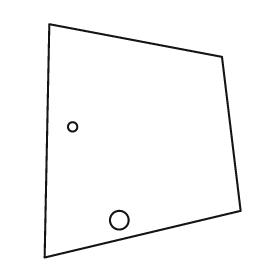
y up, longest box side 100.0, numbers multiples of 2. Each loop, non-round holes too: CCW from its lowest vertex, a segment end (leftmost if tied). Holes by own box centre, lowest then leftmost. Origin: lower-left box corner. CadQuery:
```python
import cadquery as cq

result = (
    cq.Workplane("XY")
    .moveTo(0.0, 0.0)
    .lineTo(84.0, 20.0)
    .lineTo(76.0, 86.0)
    .lineTo(2.0, 100.0)
    .close()
    .moveTo(32.0, 16.0)
    .circle(4.0)
    .moveTo(12.0, 56.0)
    .circle(2.0)
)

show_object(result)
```